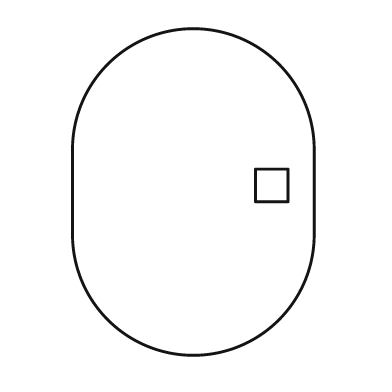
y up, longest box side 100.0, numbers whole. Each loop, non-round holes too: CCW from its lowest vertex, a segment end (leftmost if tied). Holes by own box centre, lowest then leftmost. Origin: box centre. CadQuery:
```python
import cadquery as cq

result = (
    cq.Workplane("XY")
    .moveTo(-37.0, -13.0)
    .threePointArc((0.0, -50.0), (37.0, -13.0))
    .lineTo(37.0, 13.0)
    .threePointArc((0.0, 50.0), (-37.0, 13.0))
    .close()
    .moveTo(19.0, -3.0)
    .lineTo(29.0, -3.0)
    .lineTo(29.0, 7.0)
    .lineTo(19.0, 7.0)
    .close()
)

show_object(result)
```